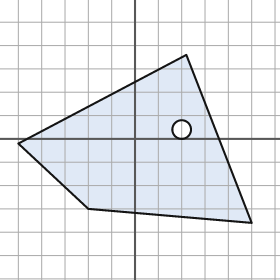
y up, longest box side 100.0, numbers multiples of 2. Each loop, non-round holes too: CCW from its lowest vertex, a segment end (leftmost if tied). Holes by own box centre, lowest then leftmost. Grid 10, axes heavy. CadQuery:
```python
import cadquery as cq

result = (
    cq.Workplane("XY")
    .moveTo(50.0, -36.0)
    .lineTo(22.0, 36.0)
    .lineTo(-50.0, -2.0)
    .lineTo(-20.0, -30.0)
    .close()
    .moveTo(20.0, 4.0)
    .circle(4.0)
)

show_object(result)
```